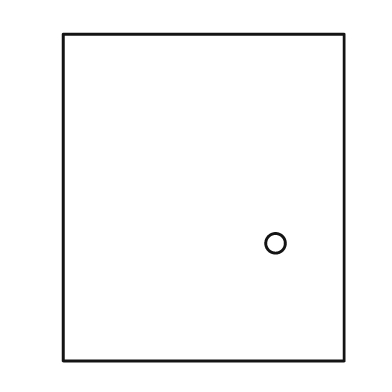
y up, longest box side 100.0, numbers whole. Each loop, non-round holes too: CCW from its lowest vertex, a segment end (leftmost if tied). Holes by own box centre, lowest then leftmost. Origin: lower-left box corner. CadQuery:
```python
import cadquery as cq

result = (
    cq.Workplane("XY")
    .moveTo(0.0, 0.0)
    .lineTo(86.0, 0.0)
    .lineTo(86.0, 100.0)
    .lineTo(0.0, 100.0)
    .close()
    .moveTo(65.0, 36.0)
    .circle(3.0)
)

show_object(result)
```